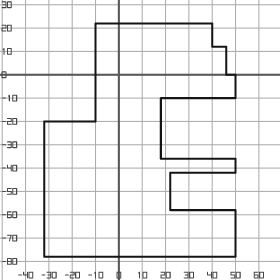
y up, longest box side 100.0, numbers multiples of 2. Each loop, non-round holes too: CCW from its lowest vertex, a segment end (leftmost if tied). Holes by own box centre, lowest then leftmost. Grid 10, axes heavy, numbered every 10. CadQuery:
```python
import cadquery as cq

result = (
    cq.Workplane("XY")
    .moveTo(-32.0, -78.0)
    .lineTo(50.0, -78.0)
    .lineTo(50.0, -58.0)
    .lineTo(22.0, -58.0)
    .lineTo(22.0, -42.0)
    .lineTo(50.0, -42.0)
    .lineTo(50.0, -36.0)
    .lineTo(18.0, -36.0)
    .lineTo(18.0, -10.0)
    .lineTo(50.0, -10.0)
    .lineTo(50.0, 0.0)
    .lineTo(46.0, 0.0)
    .lineTo(46.0, 12.0)
    .lineTo(40.0, 12.0)
    .lineTo(40.0, 22.0)
    .lineTo(-10.0, 22.0)
    .lineTo(-10.0, -20.0)
    .lineTo(-32.0, -20.0)
    .close()
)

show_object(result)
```